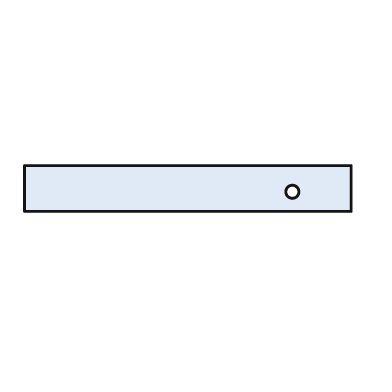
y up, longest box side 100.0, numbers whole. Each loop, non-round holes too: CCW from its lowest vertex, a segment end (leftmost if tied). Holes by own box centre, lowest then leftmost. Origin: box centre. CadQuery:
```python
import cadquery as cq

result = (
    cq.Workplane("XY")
    .moveTo(-50.0, -7.0)
    .lineTo(50.0, -7.0)
    .lineTo(50.0, 7.0)
    .lineTo(-50.0, 7.0)
    .close()
    .moveTo(32.0, -1.0)
    .circle(2.0)
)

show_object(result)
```